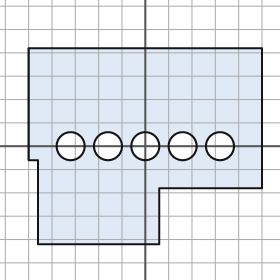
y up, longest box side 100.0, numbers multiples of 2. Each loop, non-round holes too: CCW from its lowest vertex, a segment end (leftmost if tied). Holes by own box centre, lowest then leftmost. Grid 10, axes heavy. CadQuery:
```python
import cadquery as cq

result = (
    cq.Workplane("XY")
    .moveTo(-46.0, -42.0)
    .lineTo(6.0, -42.0)
    .lineTo(6.0, -18.0)
    .lineTo(50.0, -18.0)
    .lineTo(50.0, 42.0)
    .lineTo(-50.0, 42.0)
    .lineTo(-50.0, -6.0)
    .lineTo(-46.0, -6.0)
    .close()
    .moveTo(-32.0, 0.0)
    .circle(6.0)
    .moveTo(-16.0, 0.0)
    .circle(6.0)
    .moveTo(0.0, 0.0)
    .circle(6.0)
    .moveTo(16.0, 0.0)
    .circle(6.0)
    .moveTo(32.0, 0.0)
    .circle(6.0)
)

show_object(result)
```